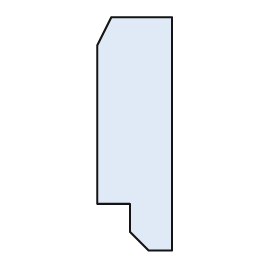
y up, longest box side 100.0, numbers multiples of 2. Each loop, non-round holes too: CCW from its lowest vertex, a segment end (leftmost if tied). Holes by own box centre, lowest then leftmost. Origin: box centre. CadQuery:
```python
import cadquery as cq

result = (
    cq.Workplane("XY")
    .moveTo(6.0, -50.0)
    .lineTo(16.0, -50.0)
    .lineTo(16.0, 50.0)
    .lineTo(-10.0, 50.0)
    .lineTo(-16.0, 38.0)
    .lineTo(-16.0, -30.0)
    .lineTo(-2.0, -30.0)
    .lineTo(-2.0, -42.0)
    .close()
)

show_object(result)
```